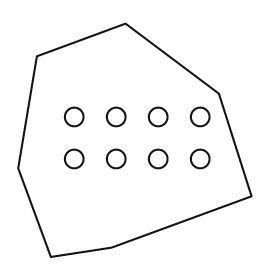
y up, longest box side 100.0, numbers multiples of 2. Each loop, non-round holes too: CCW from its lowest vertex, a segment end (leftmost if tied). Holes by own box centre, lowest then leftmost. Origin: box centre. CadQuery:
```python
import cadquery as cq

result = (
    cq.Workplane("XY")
    .moveTo(-36.0, -50.0)
    .lineTo(-10.0, -46.0)
    .lineTo(50.0, -24.0)
    .lineTo(36.0, 20.0)
    .lineTo(-4.0, 50.0)
    .lineTo(-42.0, 36.0)
    .lineTo(-50.0, -12.0)
    .close()
    .moveTo(-26.0, -8.0)
    .circle(4.0)
    .moveTo(-8.0, -8.0)
    .circle(4.0)
    .moveTo(10.0, -8.0)
    .circle(4.0)
    .moveTo(28.0, -8.0)
    .circle(4.0)
    .moveTo(-26.0, 10.0)
    .circle(4.0)
    .moveTo(-8.0, 10.0)
    .circle(4.0)
    .moveTo(10.0, 10.0)
    .circle(4.0)
    .moveTo(28.0, 10.0)
    .circle(4.0)
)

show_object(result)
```